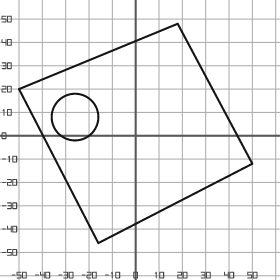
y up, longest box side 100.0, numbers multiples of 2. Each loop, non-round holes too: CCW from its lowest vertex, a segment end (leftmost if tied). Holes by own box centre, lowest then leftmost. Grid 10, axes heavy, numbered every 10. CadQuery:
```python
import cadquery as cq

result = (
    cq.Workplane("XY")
    .moveTo(-16.0, -46.0)
    .lineTo(50.0, -12.0)
    .lineTo(18.0, 48.0)
    .lineTo(-50.0, 20.0)
    .close()
    .moveTo(-26.0, 8.0)
    .circle(10.0)
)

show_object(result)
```